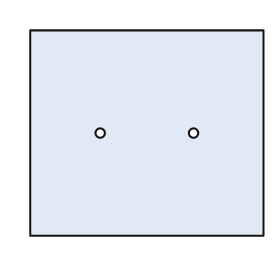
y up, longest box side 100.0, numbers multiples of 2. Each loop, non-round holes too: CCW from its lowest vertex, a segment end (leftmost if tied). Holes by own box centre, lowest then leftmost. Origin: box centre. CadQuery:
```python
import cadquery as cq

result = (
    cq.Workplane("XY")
    .moveTo(-50.0, -44.0)
    .lineTo(50.0, -44.0)
    .lineTo(50.0, 44.0)
    .lineTo(-50.0, 44.0)
    .close()
    .moveTo(-20.0, 0.0)
    .circle(2.0)
    .moveTo(20.0, 0.0)
    .circle(2.0)
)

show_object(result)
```